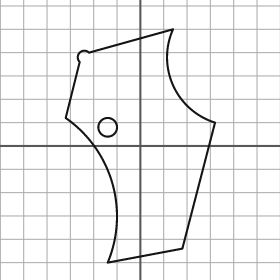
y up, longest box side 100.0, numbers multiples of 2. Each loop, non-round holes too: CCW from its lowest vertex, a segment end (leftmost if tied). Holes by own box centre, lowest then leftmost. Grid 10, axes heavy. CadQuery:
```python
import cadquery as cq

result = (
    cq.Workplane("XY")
    .moveTo(-14.0, -50.0)
    .lineTo(18.0, -44.0)
    .lineTo(32.0, 10.0)
    .threePointArc((14.0, 26.0), (14.0, 50.0))
    .lineTo(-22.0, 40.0)
    .threePointArc((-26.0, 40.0), (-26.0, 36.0))
    .lineTo(-32.0, 12.0)
    .threePointArc((-12.0, -16.0), (-14.0, -50.0))
    .close()
    .moveTo(-14.0, 8.0)
    .circle(4.0)
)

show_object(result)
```